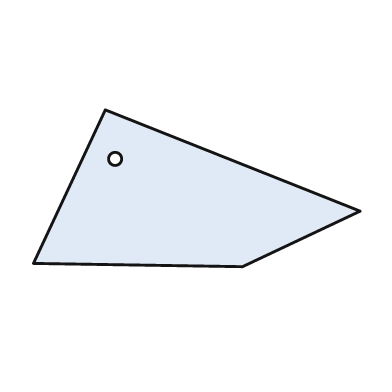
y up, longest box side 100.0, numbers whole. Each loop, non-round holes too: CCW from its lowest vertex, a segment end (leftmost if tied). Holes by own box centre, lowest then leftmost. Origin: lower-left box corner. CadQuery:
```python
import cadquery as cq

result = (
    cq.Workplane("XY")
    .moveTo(64.0, 0.0)
    .lineTo(100.0, 17.0)
    .lineTo(22.0, 48.0)
    .lineTo(0.0, 1.0)
    .close()
    .moveTo(25.0, 33.0)
    .circle(2.0)
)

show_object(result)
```